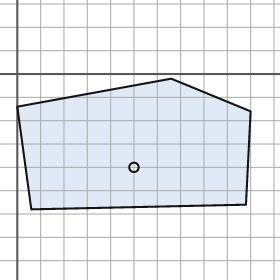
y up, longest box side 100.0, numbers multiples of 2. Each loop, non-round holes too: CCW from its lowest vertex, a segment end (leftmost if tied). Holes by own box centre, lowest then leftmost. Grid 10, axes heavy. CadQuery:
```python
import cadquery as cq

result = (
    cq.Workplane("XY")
    .moveTo(6.0, -58.0)
    .lineTo(98.0, -56.0)
    .lineTo(100.0, -16.0)
    .lineTo(66.0, -2.0)
    .lineTo(0.0, -14.0)
    .close()
    .moveTo(50.0, -40.0)
    .circle(2.0)
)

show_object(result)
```